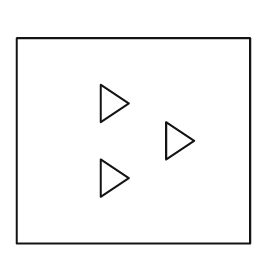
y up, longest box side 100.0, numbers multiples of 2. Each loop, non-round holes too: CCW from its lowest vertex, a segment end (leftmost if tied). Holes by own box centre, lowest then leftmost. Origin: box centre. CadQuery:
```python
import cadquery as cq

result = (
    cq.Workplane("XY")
    .moveTo(-50.0, -44.0)
    .lineTo(50.0, -44.0)
    .lineTo(50.0, 44.0)
    .lineTo(-50.0, 44.0)
    .close()
    .moveTo(-14.0, -24.0)
    .lineTo(-2.0, -16.0)
    .lineTo(-14.0, -8.0)
    .close()
    .moveTo(14.0, -8.0)
    .lineTo(26.0, 0.0)
    .lineTo(14.0, 8.0)
    .close()
    .moveTo(-14.0, 8.0)
    .lineTo(-2.0, 16.0)
    .lineTo(-14.0, 24.0)
    .close()
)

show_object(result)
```